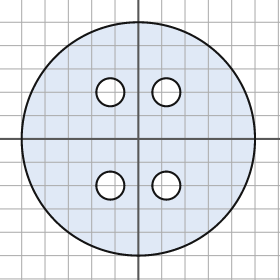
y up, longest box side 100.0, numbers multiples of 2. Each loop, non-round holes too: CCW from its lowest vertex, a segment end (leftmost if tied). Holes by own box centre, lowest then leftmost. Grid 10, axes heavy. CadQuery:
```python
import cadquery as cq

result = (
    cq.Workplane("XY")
    .moveTo(0.0, 0.0)
    .circle(50.0)
    .moveTo(-12.0, -20.0)
    .circle(6.0)
    .moveTo(12.0, -20.0)
    .circle(6.0)
    .moveTo(-12.0, 20.0)
    .circle(6.0)
    .moveTo(12.0, 20.0)
    .circle(6.0)
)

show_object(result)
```